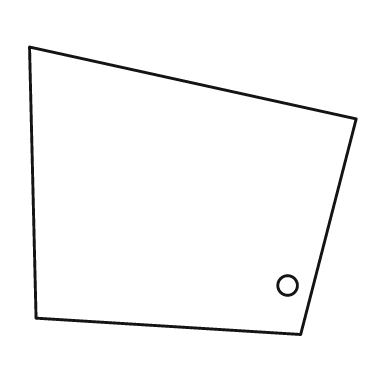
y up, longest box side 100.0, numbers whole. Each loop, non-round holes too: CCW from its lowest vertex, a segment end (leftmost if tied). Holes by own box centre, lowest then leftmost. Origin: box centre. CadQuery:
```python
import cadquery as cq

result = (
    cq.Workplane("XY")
    .moveTo(33.0, -44.0)
    .lineTo(50.0, 22.0)
    .lineTo(-50.0, 44.0)
    .lineTo(-48.0, -39.0)
    .close()
    .moveTo(29.0, -29.0)
    .circle(3.0)
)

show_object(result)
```